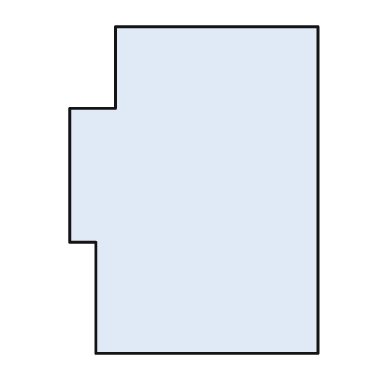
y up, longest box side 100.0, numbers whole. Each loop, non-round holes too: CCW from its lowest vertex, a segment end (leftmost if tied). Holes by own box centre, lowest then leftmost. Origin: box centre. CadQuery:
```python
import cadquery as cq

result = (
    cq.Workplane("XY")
    .moveTo(-30.0, -50.0)
    .lineTo(38.0, -50.0)
    .lineTo(38.0, 50.0)
    .lineTo(-24.0, 50.0)
    .lineTo(-24.0, 25.0)
    .lineTo(-38.0, 25.0)
    .lineTo(-38.0, -16.0)
    .lineTo(-30.0, -16.0)
    .close()
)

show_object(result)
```